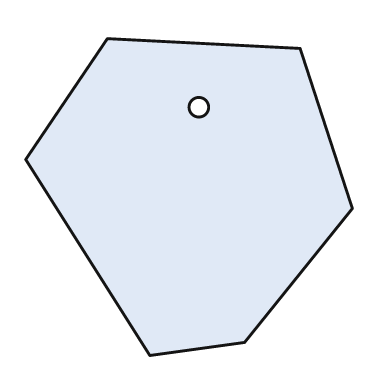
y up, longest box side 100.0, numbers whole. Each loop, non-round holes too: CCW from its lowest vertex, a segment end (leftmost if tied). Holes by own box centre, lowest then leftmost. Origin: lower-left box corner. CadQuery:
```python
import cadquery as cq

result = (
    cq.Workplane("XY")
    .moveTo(38.0, 0.0)
    .lineTo(67.0, 4.0)
    .lineTo(100.0, 45.0)
    .lineTo(84.0, 94.0)
    .lineTo(25.0, 97.0)
    .lineTo(0.0, 60.0)
    .close()
    .moveTo(53.0, 76.0)
    .circle(3.0)
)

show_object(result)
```